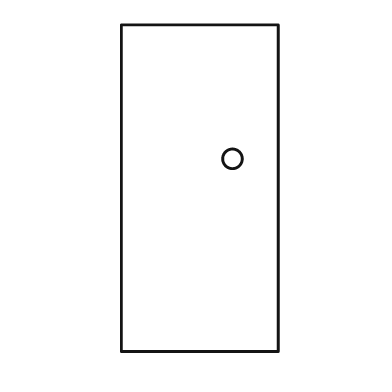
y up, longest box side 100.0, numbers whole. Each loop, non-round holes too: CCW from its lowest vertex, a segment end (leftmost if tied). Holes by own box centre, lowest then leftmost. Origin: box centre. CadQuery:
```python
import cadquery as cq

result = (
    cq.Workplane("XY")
    .moveTo(-24.0, -50.0)
    .lineTo(24.0, -50.0)
    .lineTo(24.0, 50.0)
    .lineTo(-24.0, 50.0)
    .close()
    .moveTo(10.0, 9.0)
    .circle(3.0)
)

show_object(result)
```